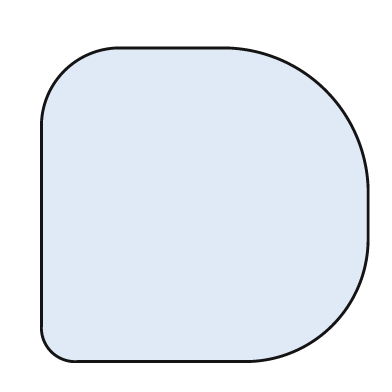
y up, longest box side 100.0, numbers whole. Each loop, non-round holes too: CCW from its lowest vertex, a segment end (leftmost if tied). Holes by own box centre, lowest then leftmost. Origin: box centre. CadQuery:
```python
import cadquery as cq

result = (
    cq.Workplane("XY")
    .moveTo(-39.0, -48.0)
    .lineTo(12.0, -48.0)
    .threePointArc((39.0, -37.0), (50.0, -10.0))
    .lineTo(50.0, 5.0)
    .threePointArc((37.0, 35.0), (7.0, 48.0))
    .lineTo(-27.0, 48.0)
    .threePointArc((-43.0, 41.0), (-50.0, 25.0))
    .lineTo(-50.0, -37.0)
    .threePointArc((-47.0, -45.0), (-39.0, -48.0))
    .close()
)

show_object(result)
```